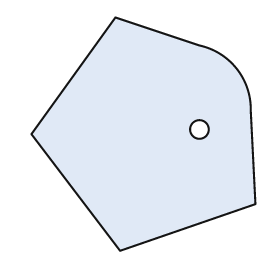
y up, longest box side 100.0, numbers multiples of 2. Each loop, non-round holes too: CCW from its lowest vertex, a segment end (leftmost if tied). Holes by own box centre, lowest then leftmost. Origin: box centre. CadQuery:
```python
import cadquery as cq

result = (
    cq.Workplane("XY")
    .moveTo(-10.0, -50.0)
    .lineTo(48.0, -30.0)
    .lineTo(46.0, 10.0)
    .threePointArc((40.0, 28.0), (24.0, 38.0))
    .lineTo(-12.0, 50.0)
    .lineTo(-48.0, 0.0)
    .close()
    .moveTo(24.0, 2.0)
    .circle(4.0)
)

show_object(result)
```